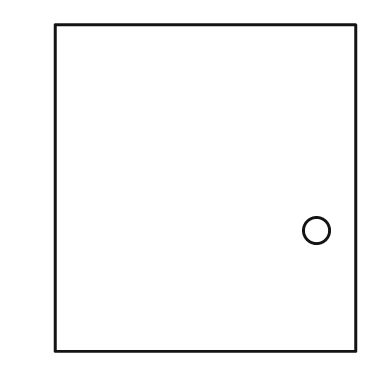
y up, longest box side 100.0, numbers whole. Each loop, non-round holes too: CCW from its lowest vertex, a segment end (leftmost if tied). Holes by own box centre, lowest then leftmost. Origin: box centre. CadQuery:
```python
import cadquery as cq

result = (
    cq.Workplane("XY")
    .moveTo(-46.0, -50.0)
    .lineTo(46.0, -50.0)
    .lineTo(46.0, 50.0)
    .lineTo(-46.0, 50.0)
    .close()
    .moveTo(34.0, -13.0)
    .circle(4.0)
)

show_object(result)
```